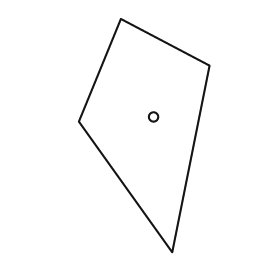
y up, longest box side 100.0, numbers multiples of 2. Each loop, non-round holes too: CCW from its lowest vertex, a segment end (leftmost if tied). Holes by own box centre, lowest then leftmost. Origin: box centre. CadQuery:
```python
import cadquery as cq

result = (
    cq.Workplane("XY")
    .moveTo(12.0, -50.0)
    .lineTo(28.0, 30.0)
    .lineTo(-10.0, 50.0)
    .lineTo(-28.0, 6.0)
    .close()
    .moveTo(4.0, 8.0)
    .circle(2.0)
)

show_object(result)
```